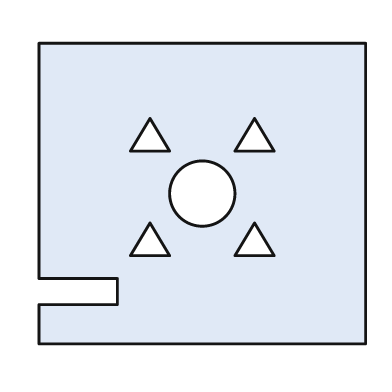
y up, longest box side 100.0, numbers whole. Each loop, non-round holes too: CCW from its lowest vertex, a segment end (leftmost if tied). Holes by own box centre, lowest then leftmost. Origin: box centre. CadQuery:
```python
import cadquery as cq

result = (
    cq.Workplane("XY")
    .moveTo(-50.0, -46.0)
    .lineTo(50.0, -46.0)
    .lineTo(50.0, 46.0)
    .lineTo(-50.0, 46.0)
    .lineTo(-50.0, -26.0)
    .lineTo(-26.0, -26.0)
    .lineTo(-26.0, -34.0)
    .lineTo(-50.0, -34.0)
    .close()
    .moveTo(-22.0, -19.0)
    .lineTo(-10.0, -19.0)
    .lineTo(-16.0, -9.0)
    .close()
    .moveTo(10.0, -19.0)
    .lineTo(22.0, -19.0)
    .lineTo(16.0, -9.0)
    .close()
    .moveTo(0.0, 0.0)
    .circle(10.0)
    .moveTo(-22.0, 13.0)
    .lineTo(-10.0, 13.0)
    .lineTo(-16.0, 23.0)
    .close()
    .moveTo(10.0, 13.0)
    .lineTo(22.0, 13.0)
    .lineTo(16.0, 23.0)
    .close()
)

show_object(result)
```